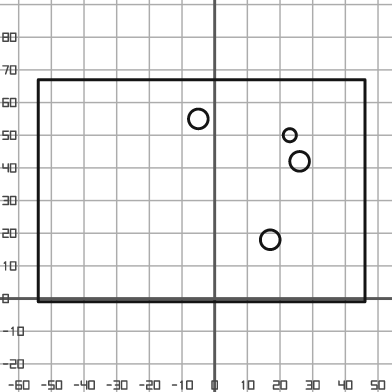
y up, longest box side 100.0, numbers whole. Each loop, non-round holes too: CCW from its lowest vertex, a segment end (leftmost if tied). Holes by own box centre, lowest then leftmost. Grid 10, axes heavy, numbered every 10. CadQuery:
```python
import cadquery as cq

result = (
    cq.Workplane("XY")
    .moveTo(-54.0, -1.0)
    .lineTo(46.0, -1.0)
    .lineTo(46.0, 67.0)
    .lineTo(-54.0, 67.0)
    .close()
    .moveTo(17.0, 18.0)
    .circle(3.0)
    .moveTo(26.0, 42.0)
    .circle(3.0)
    .moveTo(23.0, 50.0)
    .circle(2.0)
    .moveTo(-5.0, 55.0)
    .circle(3.0)
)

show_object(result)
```